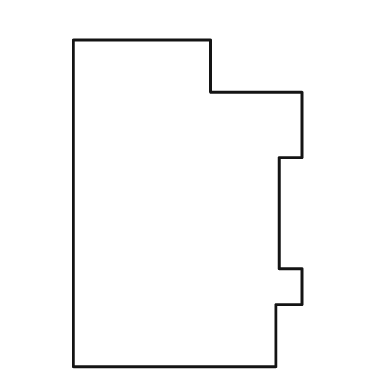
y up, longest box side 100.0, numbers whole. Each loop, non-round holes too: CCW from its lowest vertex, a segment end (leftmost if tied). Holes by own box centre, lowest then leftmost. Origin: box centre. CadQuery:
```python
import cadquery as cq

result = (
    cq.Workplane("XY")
    .moveTo(-35.0, -50.0)
    .lineTo(27.0, -50.0)
    .lineTo(27.0, -31.0)
    .lineTo(35.0, -31.0)
    .lineTo(35.0, -20.0)
    .lineTo(28.0, -20.0)
    .lineTo(28.0, 14.0)
    .lineTo(35.0, 14.0)
    .lineTo(35.0, 34.0)
    .lineTo(7.0, 34.0)
    .lineTo(7.0, 50.0)
    .lineTo(-35.0, 50.0)
    .close()
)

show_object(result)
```